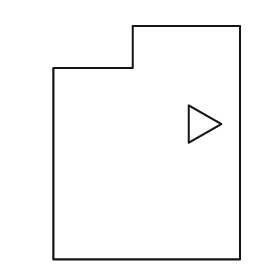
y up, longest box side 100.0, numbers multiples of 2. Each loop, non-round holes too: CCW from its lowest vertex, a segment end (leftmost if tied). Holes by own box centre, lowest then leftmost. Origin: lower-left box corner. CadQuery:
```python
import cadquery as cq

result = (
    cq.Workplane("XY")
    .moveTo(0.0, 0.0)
    .lineTo(80.0, 0.0)
    .lineTo(80.0, 100.0)
    .lineTo(34.0, 100.0)
    .lineTo(34.0, 82.0)
    .lineTo(0.0, 82.0)
    .close()
    .moveTo(58.0, 50.0)
    .lineTo(72.0, 58.0)
    .lineTo(58.0, 66.0)
    .close()
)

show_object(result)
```